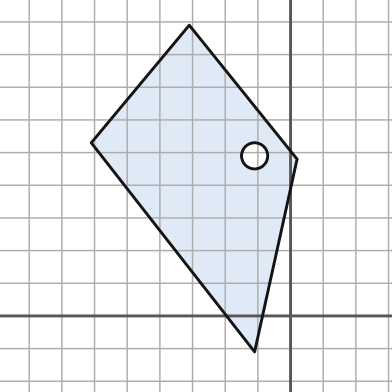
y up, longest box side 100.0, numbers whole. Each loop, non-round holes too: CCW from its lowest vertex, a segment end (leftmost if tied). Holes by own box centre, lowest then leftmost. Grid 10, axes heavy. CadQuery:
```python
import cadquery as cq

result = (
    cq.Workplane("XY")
    .moveTo(-11.0, -11.0)
    .lineTo(2.0, 48.0)
    .lineTo(-31.0, 89.0)
    .lineTo(-61.0, 53.0)
    .close()
    .moveTo(-11.0, 49.0)
    .circle(4.0)
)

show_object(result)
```